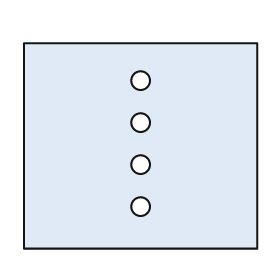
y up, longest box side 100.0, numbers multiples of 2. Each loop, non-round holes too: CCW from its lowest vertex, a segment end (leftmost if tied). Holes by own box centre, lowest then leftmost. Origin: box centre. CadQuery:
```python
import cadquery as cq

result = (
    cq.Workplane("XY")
    .moveTo(-50.0, -44.0)
    .lineTo(50.0, -44.0)
    .lineTo(50.0, 44.0)
    .lineTo(-50.0, 44.0)
    .close()
    .moveTo(0.0, -26.0)
    .circle(4.0)
    .moveTo(0.0, -8.0)
    .circle(4.0)
    .moveTo(0.0, 10.0)
    .circle(4.0)
    .moveTo(0.0, 28.0)
    .circle(4.0)
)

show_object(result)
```